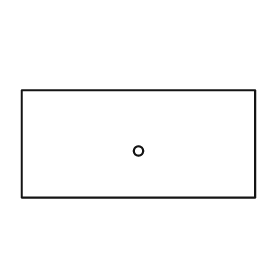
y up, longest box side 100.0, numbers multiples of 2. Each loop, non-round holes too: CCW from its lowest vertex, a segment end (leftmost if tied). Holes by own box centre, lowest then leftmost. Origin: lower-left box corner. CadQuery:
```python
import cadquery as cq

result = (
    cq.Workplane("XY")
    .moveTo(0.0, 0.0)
    .lineTo(100.0, 0.0)
    .lineTo(100.0, 46.0)
    .lineTo(0.0, 46.0)
    .close()
    .moveTo(50.0, 20.0)
    .circle(2.0)
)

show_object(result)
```